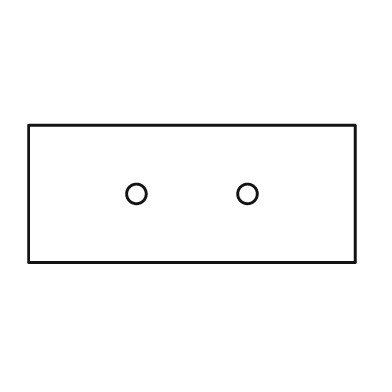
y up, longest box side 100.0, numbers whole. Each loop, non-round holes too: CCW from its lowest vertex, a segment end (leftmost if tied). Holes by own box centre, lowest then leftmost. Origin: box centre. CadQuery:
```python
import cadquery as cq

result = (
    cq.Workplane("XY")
    .moveTo(-50.0, -21.0)
    .lineTo(50.0, -21.0)
    .lineTo(50.0, 21.0)
    .lineTo(-50.0, 21.0)
    .close()
    .moveTo(-17.0, 0.0)
    .circle(3.0)
    .moveTo(17.0, 0.0)
    .circle(3.0)
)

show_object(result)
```